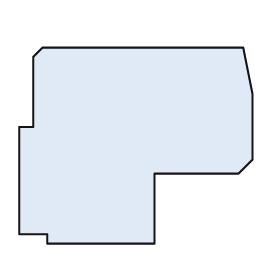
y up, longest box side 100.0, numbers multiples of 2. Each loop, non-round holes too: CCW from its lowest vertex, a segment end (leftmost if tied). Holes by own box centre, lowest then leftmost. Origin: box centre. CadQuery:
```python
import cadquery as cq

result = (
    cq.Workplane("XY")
    .moveTo(-38.0, -42.0)
    .lineTo(8.0, -42.0)
    .lineTo(8.0, -12.0)
    .lineTo(44.0, -12.0)
    .lineTo(50.0, -6.0)
    .lineTo(50.0, 22.0)
    .lineTo(46.0, 42.0)
    .lineTo(-40.0, 42.0)
    .lineTo(-44.0, 38.0)
    .lineTo(-44.0, 8.0)
    .lineTo(-50.0, 8.0)
    .lineTo(-50.0, -38.0)
    .lineTo(-38.0, -38.0)
    .close()
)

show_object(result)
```